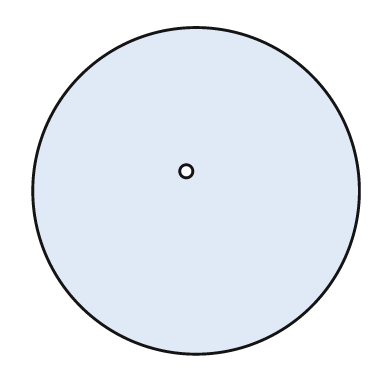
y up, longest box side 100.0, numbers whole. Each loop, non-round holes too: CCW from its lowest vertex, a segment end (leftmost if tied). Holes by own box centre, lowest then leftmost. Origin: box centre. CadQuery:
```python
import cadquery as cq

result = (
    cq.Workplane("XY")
    .moveTo(0.0, 0.0)
    .circle(50.0)
    .moveTo(-3.0, 6.0)
    .circle(2.0)
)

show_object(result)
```